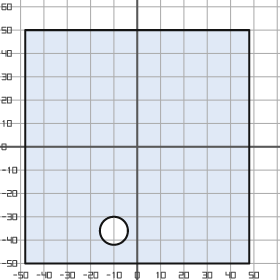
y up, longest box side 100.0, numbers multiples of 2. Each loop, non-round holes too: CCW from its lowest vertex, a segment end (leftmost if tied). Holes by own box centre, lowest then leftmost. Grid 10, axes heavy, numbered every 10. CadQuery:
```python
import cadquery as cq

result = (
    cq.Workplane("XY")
    .moveTo(-48.0, -50.0)
    .lineTo(48.0, -50.0)
    .lineTo(48.0, 50.0)
    .lineTo(-48.0, 50.0)
    .close()
    .moveTo(-10.0, -36.0)
    .circle(6.0)
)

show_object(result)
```